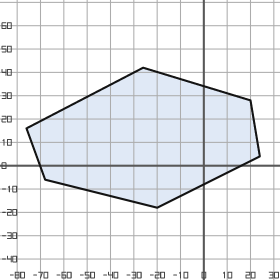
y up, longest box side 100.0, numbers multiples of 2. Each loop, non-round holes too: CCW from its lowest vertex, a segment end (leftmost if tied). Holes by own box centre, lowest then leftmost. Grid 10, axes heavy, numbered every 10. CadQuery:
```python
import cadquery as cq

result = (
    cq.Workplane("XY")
    .moveTo(-20.0, -18.0)
    .lineTo(24.0, 4.0)
    .lineTo(20.0, 28.0)
    .lineTo(-26.0, 42.0)
    .lineTo(-76.0, 16.0)
    .lineTo(-68.0, -6.0)
    .close()
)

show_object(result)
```